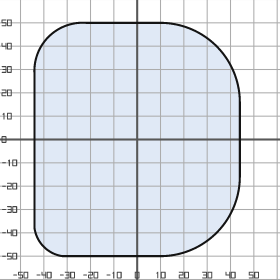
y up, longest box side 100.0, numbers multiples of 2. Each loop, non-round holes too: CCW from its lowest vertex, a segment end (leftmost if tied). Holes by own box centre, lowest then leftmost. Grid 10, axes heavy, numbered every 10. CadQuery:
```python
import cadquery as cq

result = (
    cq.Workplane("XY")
    .moveTo(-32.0, -50.0)
    .lineTo(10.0, -50.0)
    .threePointArc((34.0, -40.0), (44.0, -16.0))
    .lineTo(44.0, 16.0)
    .threePointArc((34.0, 40.0), (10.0, 50.0))
    .lineTo(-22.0, 50.0)
    .threePointArc((-38.0, 44.0), (-44.0, 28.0))
    .lineTo(-44.0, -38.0)
    .threePointArc((-40.0, -46.0), (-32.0, -50.0))
    .close()
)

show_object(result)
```